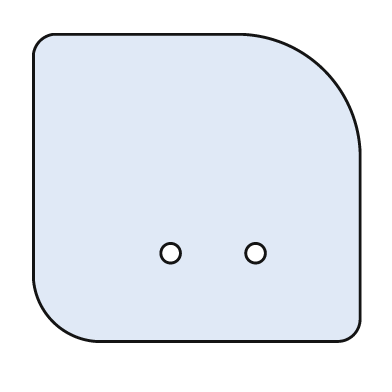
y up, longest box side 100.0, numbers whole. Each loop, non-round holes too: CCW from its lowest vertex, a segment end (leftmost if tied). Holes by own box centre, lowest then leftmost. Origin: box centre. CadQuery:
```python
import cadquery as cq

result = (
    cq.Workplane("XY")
    .moveTo(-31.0, -47.0)
    .lineTo(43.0, -47.0)
    .threePointArc((48.0, -45.0), (50.0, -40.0))
    .lineTo(50.0, 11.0)
    .threePointArc((39.0, 36.0), (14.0, 47.0))
    .lineTo(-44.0, 47.0)
    .threePointArc((-48.0, 45.0), (-50.0, 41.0))
    .lineTo(-50.0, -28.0)
    .threePointArc((-44.0, -41.0), (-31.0, -47.0))
    .close()
    .moveTo(-8.0, -20.0)
    .circle(3.0)
    .moveTo(18.0, -20.0)
    .circle(3.0)
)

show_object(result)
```